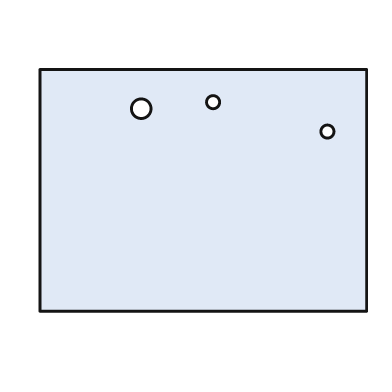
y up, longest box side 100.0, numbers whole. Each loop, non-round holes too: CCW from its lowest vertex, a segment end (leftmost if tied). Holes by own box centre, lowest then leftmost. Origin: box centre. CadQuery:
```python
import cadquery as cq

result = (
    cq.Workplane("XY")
    .moveTo(-50.0, -37.0)
    .lineTo(50.0, -37.0)
    .lineTo(50.0, 37.0)
    .lineTo(-50.0, 37.0)
    .close()
    .moveTo(38.0, 18.0)
    .circle(2.0)
    .moveTo(-19.0, 25.0)
    .circle(3.0)
    .moveTo(3.0, 27.0)
    .circle(2.0)
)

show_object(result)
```